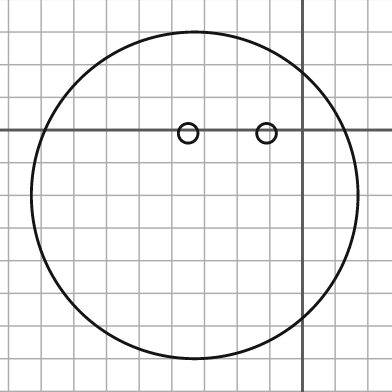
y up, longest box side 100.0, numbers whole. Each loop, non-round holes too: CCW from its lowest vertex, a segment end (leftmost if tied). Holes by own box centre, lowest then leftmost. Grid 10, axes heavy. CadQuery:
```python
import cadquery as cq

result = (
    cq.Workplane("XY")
    .moveTo(-33.0, -20.0)
    .circle(50.0)
    .moveTo(-35.0, -1.0)
    .circle(3.0)
    .moveTo(-11.0, -1.0)
    .circle(3.0)
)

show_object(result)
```